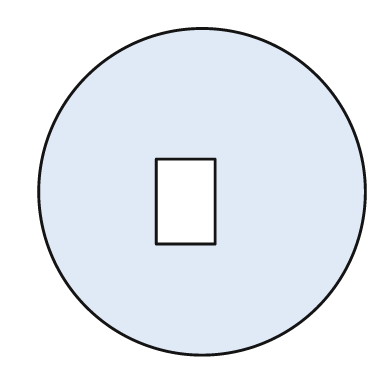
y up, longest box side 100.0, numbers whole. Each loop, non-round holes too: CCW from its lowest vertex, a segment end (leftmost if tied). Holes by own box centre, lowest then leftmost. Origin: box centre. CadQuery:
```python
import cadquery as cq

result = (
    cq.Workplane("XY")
    .moveTo(0.0, 0.0)
    .circle(50.0)
    .moveTo(-14.0, -16.0)
    .lineTo(4.0, -16.0)
    .lineTo(4.0, 10.0)
    .lineTo(-14.0, 10.0)
    .close()
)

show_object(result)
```